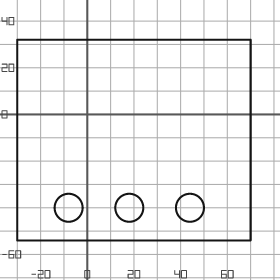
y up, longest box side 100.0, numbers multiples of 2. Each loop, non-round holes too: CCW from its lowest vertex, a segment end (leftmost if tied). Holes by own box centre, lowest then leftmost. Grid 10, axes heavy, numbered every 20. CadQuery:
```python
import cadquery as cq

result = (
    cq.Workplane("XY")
    .moveTo(-30.0, -54.0)
    .lineTo(70.0, -54.0)
    .lineTo(70.0, 32.0)
    .lineTo(-30.0, 32.0)
    .close()
    .moveTo(-8.0, -40.0)
    .circle(6.0)
    .moveTo(18.0, -40.0)
    .circle(6.0)
    .moveTo(44.0, -40.0)
    .circle(6.0)
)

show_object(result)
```